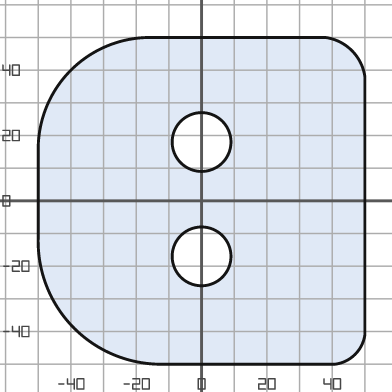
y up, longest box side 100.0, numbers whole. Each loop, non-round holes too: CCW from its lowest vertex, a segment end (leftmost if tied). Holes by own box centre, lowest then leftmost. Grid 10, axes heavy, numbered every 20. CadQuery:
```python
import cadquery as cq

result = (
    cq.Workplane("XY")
    .moveTo(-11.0, -50.0)
    .lineTo(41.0, -50.0)
    .threePointArc((47.0, -47.0), (50.0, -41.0))
    .lineTo(50.0, 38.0)
    .threePointArc((46.0, 46.0), (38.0, 50.0))
    .lineTo(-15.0, 50.0)
    .threePointArc((-40.0, 40.0), (-50.0, 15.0))
    .lineTo(-50.0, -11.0)
    .threePointArc((-39.0, -39.0), (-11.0, -50.0))
    .close()
    .moveTo(0.0, -17.0)
    .circle(9.0)
    .moveTo(0.0, 18.0)
    .circle(9.0)
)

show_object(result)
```